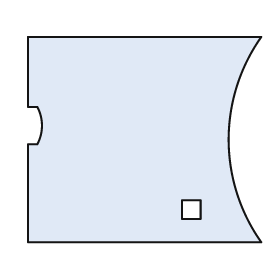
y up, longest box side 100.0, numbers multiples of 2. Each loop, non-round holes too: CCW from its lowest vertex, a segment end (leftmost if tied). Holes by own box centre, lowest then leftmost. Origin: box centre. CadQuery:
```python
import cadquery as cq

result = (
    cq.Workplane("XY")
    .moveTo(-50.0, -44.0)
    .lineTo(50.0, -44.0)
    .threePointArc((36.0, 0.0), (50.0, 44.0))
    .lineTo(-50.0, 44.0)
    .lineTo(-50.0, 14.0)
    .lineTo(-46.0, 14.0)
    .threePointArc((-44.0, 6.0), (-46.0, -2.0))
    .lineTo(-50.0, -2.0)
    .close()
    .moveTo(16.0, -34.0)
    .lineTo(24.0, -34.0)
    .lineTo(24.0, -26.0)
    .lineTo(16.0, -26.0)
    .close()
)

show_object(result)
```